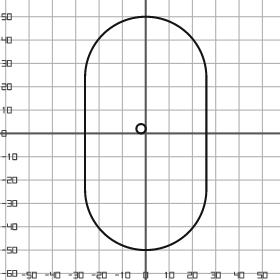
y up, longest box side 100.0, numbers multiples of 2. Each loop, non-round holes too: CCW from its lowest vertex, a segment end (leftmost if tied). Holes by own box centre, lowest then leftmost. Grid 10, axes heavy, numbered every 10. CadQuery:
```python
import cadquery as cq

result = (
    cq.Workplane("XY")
    .moveTo(-26.0, -24.0)
    .threePointArc((0.0, -50.0), (26.0, -24.0))
    .lineTo(26.0, 24.0)
    .threePointArc((0.0, 50.0), (-26.0, 24.0))
    .close()
    .moveTo(-2.0, 2.0)
    .circle(2.0)
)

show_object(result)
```